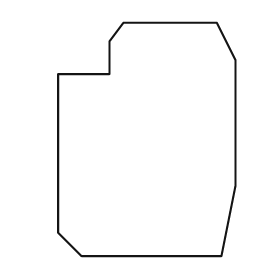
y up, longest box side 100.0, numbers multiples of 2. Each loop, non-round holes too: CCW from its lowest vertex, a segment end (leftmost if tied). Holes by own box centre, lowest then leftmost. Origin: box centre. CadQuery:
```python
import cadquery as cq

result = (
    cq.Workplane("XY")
    .moveTo(-28.0, -50.0)
    .lineTo(32.0, -50.0)
    .lineTo(38.0, -20.0)
    .lineTo(38.0, 34.0)
    .lineTo(30.0, 50.0)
    .lineTo(-10.0, 50.0)
    .lineTo(-16.0, 42.0)
    .lineTo(-16.0, 28.0)
    .lineTo(-38.0, 28.0)
    .lineTo(-38.0, -40.0)
    .close()
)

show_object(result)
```